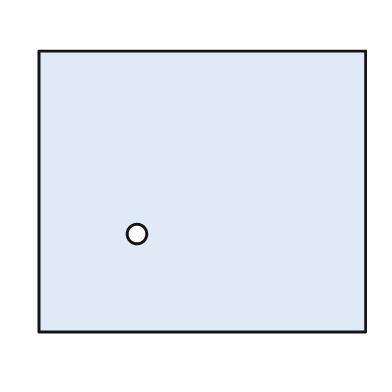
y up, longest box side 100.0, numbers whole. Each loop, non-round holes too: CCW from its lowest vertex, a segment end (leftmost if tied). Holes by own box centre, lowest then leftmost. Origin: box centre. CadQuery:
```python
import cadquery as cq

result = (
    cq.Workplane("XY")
    .moveTo(-50.0, -43.0)
    .lineTo(50.0, -43.0)
    .lineTo(50.0, 43.0)
    .lineTo(-50.0, 43.0)
    .close()
    .moveTo(-20.0, -13.0)
    .circle(3.0)
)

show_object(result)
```